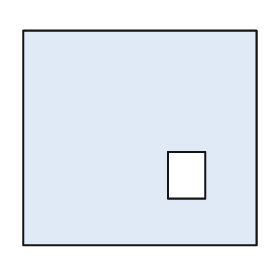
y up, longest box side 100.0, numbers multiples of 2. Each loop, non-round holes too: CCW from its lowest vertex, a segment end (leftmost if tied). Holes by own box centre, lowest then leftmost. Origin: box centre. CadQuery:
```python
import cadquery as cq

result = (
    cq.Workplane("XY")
    .moveTo(-50.0, -46.0)
    .lineTo(50.0, -46.0)
    .lineTo(50.0, 46.0)
    .lineTo(-50.0, 46.0)
    .close()
    .moveTo(12.0, -26.0)
    .lineTo(28.0, -26.0)
    .lineTo(28.0, -6.0)
    .lineTo(12.0, -6.0)
    .close()
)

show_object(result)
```